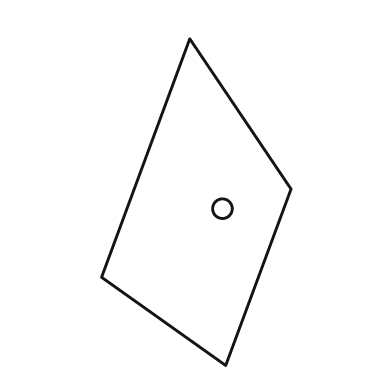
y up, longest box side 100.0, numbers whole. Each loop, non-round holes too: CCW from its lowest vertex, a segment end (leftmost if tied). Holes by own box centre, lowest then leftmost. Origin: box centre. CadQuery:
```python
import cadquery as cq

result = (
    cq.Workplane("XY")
    .moveTo(9.0, -50.0)
    .lineTo(29.0, 4.0)
    .lineTo(-2.0, 50.0)
    .lineTo(-29.0, -23.0)
    .close()
    .moveTo(8.0, -2.0)
    .circle(3.0)
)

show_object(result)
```